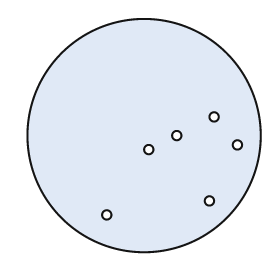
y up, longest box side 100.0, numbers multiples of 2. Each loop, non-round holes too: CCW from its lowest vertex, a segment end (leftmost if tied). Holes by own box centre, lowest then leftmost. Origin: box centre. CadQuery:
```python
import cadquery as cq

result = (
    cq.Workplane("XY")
    .moveTo(0.0, 0.0)
    .circle(50.0)
    .moveTo(-16.0, -34.0)
    .circle(2.0)
    .moveTo(28.0, -28.0)
    .circle(2.0)
    .moveTo(2.0, -6.0)
    .circle(2.0)
    .moveTo(40.0, -4.0)
    .circle(2.0)
    .moveTo(14.0, 0.0)
    .circle(2.0)
    .moveTo(30.0, 8.0)
    .circle(2.0)
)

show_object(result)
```